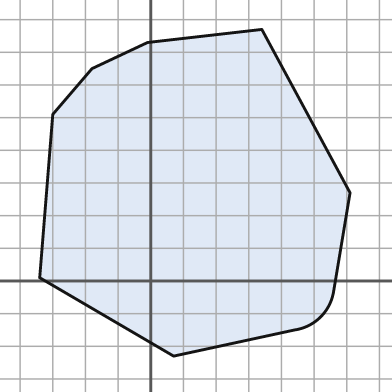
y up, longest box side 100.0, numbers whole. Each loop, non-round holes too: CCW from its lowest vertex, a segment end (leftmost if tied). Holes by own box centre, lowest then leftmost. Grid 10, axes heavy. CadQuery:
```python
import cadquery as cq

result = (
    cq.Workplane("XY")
    .moveTo(7.0, -23.0)
    .lineTo(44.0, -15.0)
    .threePointArc((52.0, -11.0), (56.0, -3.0))
    .lineTo(61.0, 27.0)
    .lineTo(34.0, 77.0)
    .lineTo(-1.0, 73.0)
    .lineTo(-18.0, 65.0)
    .lineTo(-30.0, 51.0)
    .lineTo(-34.0, 1.0)
    .close()
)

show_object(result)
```